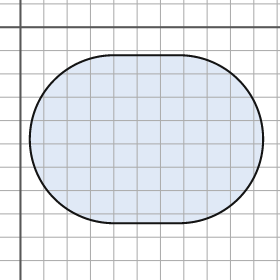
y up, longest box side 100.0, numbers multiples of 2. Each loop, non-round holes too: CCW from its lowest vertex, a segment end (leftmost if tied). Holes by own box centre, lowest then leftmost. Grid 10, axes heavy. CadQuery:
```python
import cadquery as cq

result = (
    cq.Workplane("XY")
    .moveTo(40.0, -84.0)
    .lineTo(68.0, -84.0)
    .threePointArc((104.0, -48.0), (68.0, -12.0))
    .lineTo(40.0, -12.0)
    .threePointArc((4.0, -48.0), (40.0, -84.0))
    .close()
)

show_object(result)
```